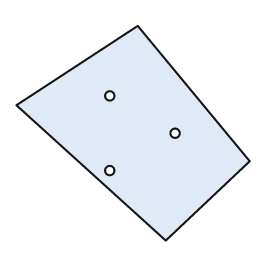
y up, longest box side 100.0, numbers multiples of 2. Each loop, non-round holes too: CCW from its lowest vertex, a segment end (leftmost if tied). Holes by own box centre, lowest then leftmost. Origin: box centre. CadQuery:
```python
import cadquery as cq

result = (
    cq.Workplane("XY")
    .moveTo(14.0, -46.0)
    .lineTo(50.0, -12.0)
    .lineTo(2.0, 46.0)
    .lineTo(-50.0, 12.0)
    .close()
    .moveTo(-10.0, -16.0)
    .circle(2.0)
    .moveTo(18.0, 0.0)
    .circle(2.0)
    .moveTo(-10.0, 16.0)
    .circle(2.0)
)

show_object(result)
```